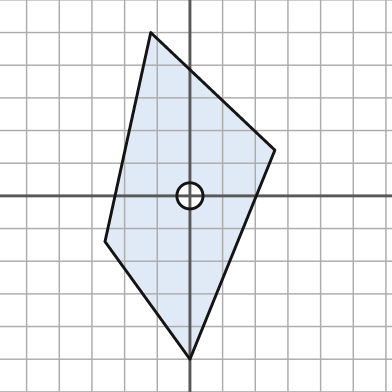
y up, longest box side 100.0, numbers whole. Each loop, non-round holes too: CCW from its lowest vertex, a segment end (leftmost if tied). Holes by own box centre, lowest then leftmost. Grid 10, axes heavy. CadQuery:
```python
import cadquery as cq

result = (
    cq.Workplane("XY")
    .moveTo(0.0, -50.0)
    .lineTo(26.0, 14.0)
    .lineTo(-12.0, 50.0)
    .lineTo(-26.0, -14.0)
    .close()
    .moveTo(0.0, 0.0)
    .circle(4.0)
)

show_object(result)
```